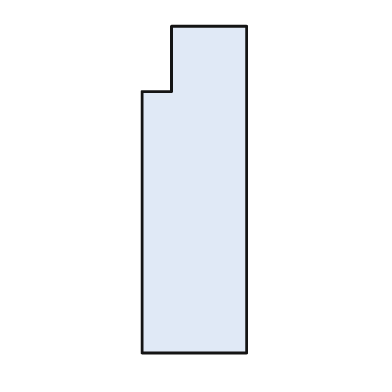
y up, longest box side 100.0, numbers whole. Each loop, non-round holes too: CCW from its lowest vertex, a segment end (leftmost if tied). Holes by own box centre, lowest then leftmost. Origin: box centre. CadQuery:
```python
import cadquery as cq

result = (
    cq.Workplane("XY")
    .moveTo(-16.0, -50.0)
    .lineTo(16.0, -50.0)
    .lineTo(16.0, 50.0)
    .lineTo(-7.0, 50.0)
    .lineTo(-7.0, 30.0)
    .lineTo(-16.0, 30.0)
    .close()
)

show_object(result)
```